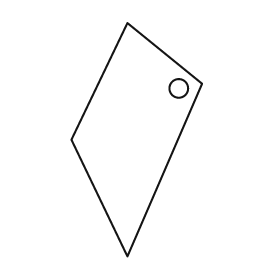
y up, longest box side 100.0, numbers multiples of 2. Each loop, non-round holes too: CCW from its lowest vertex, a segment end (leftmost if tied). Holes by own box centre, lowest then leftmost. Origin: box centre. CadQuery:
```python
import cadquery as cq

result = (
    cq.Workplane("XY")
    .moveTo(-4.0, -50.0)
    .lineTo(28.0, 24.0)
    .lineTo(-4.0, 50.0)
    .lineTo(-28.0, 0.0)
    .close()
    .moveTo(18.0, 22.0)
    .circle(4.0)
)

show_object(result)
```